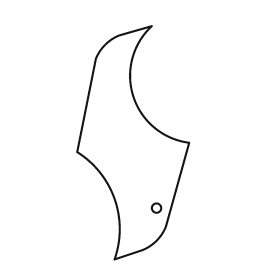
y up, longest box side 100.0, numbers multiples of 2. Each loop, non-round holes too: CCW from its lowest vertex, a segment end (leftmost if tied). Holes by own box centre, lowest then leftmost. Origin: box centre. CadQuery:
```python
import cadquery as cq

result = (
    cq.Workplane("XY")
    .moveTo(-8.0, -50.0)
    .lineTo(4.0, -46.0)
    .threePointArc((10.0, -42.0), (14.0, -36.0))
    .lineTo(24.0, 0.0)
    .threePointArc((0.0, 20.0), (8.0, 50.0))
    .lineTo(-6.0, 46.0)
    .threePointArc((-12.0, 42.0), (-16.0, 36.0))
    .lineTo(-24.0, -4.0)
    .threePointArc((-8.0, -24.0), (-8.0, -50.0))
    .close()
    .moveTo(10.0, -28.0)
    .circle(2.0)
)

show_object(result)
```